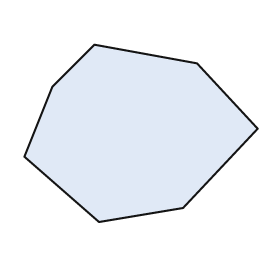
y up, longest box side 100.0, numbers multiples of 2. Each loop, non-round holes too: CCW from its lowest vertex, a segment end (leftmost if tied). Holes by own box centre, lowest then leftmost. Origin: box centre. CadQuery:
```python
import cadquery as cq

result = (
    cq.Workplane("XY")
    .moveTo(-18.0, -38.0)
    .lineTo(18.0, -32.0)
    .lineTo(50.0, 2.0)
    .lineTo(24.0, 30.0)
    .lineTo(-20.0, 38.0)
    .lineTo(-38.0, 20.0)
    .lineTo(-50.0, -10.0)
    .close()
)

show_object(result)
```